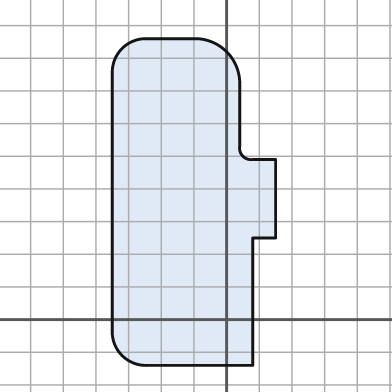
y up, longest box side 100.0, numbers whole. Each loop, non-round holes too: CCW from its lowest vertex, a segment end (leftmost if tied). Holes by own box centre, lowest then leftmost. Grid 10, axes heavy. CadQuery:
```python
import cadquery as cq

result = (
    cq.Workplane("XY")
    .moveTo(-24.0, -14.0)
    .lineTo(8.0, -14.0)
    .lineTo(8.0, 25.0)
    .lineTo(15.0, 25.0)
    .lineTo(15.0, 49.0)
    .lineTo(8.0, 49.0)
    .threePointArc((5.0, 50.0), (4.0, 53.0))
    .lineTo(4.0, 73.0)
    .threePointArc((0.0, 82.0), (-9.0, 86.0))
    .lineTo(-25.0, 86.0)
    .threePointArc((-32.0, 83.0), (-35.0, 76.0))
    .lineTo(-35.0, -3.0)
    .threePointArc((-32.0, -11.0), (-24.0, -14.0))
    .close()
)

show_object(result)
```